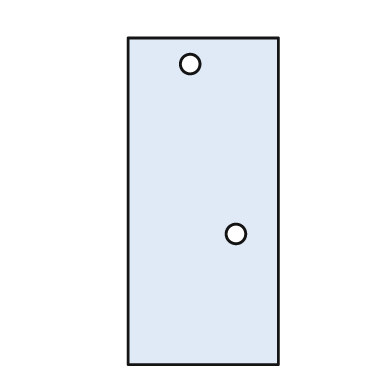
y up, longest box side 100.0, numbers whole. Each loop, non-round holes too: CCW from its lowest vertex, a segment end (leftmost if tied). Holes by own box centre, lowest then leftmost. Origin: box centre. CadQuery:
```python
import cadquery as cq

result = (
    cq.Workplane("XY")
    .moveTo(-23.0, -50.0)
    .lineTo(23.0, -50.0)
    .lineTo(23.0, 50.0)
    .lineTo(-23.0, 50.0)
    .close()
    .moveTo(10.0, -10.0)
    .circle(3.0)
    .moveTo(-4.0, 42.0)
    .circle(3.0)
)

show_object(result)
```